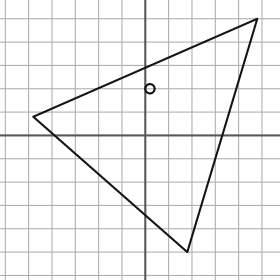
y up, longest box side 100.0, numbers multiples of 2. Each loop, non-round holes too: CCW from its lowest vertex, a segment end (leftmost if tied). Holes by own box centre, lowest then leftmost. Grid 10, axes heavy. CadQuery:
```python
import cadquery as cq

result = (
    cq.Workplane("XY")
    .moveTo(18.0, -50.0)
    .lineTo(48.0, 50.0)
    .lineTo(-48.0, 8.0)
    .close()
    .moveTo(2.0, 20.0)
    .circle(2.0)
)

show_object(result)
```